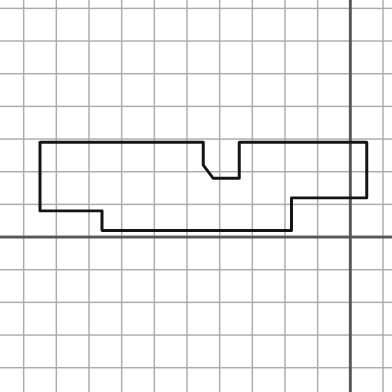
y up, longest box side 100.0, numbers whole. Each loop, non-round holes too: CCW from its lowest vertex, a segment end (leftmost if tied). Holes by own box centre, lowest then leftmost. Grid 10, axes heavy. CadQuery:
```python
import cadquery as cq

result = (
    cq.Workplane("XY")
    .moveTo(-76.0, 2.0)
    .lineTo(-18.0, 2.0)
    .lineTo(-18.0, 12.0)
    .lineTo(5.0, 12.0)
    .lineTo(5.0, 29.0)
    .lineTo(-34.0, 29.0)
    .lineTo(-34.0, 18.0)
    .lineTo(-42.0, 18.0)
    .lineTo(-45.0, 22.0)
    .lineTo(-45.0, 29.0)
    .lineTo(-95.0, 29.0)
    .lineTo(-95.0, 8.0)
    .lineTo(-76.0, 8.0)
    .close()
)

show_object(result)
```